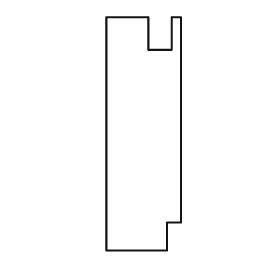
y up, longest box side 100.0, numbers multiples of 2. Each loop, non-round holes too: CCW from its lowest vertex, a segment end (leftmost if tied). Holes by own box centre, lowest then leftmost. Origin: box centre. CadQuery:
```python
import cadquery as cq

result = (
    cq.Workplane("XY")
    .moveTo(-16.0, -50.0)
    .lineTo(10.0, -50.0)
    .lineTo(10.0, -38.0)
    .lineTo(16.0, -38.0)
    .lineTo(16.0, 50.0)
    .lineTo(12.0, 50.0)
    .lineTo(12.0, 36.0)
    .lineTo(2.0, 36.0)
    .lineTo(2.0, 50.0)
    .lineTo(-16.0, 50.0)
    .close()
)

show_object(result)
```